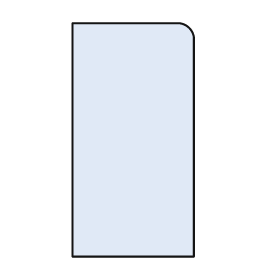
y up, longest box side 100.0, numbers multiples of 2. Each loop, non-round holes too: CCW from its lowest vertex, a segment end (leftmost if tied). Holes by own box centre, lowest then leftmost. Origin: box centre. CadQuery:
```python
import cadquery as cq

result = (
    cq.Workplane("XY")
    .moveTo(-26.0, -50.0)
    .lineTo(26.0, -50.0)
    .lineTo(26.0, 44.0)
    .threePointArc((24.0, 48.0), (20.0, 50.0))
    .lineTo(-26.0, 50.0)
    .close()
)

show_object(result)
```